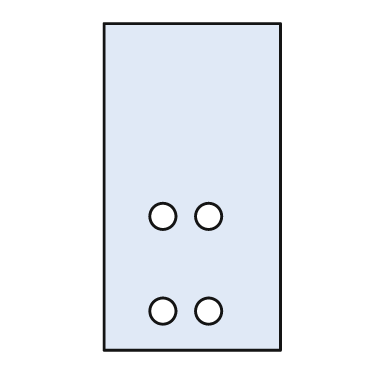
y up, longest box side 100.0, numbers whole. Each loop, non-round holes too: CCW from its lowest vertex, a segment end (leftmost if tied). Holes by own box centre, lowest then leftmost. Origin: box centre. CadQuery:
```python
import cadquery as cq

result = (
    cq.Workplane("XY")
    .moveTo(-27.0, -50.0)
    .lineTo(27.0, -50.0)
    .lineTo(27.0, 50.0)
    .lineTo(-27.0, 50.0)
    .close()
    .moveTo(-9.0, -38.0)
    .circle(4.0)
    .moveTo(5.0, -38.0)
    .circle(4.0)
    .moveTo(-9.0, -9.0)
    .circle(4.0)
    .moveTo(5.0, -9.0)
    .circle(4.0)
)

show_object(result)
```